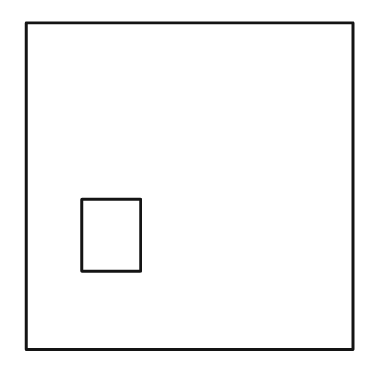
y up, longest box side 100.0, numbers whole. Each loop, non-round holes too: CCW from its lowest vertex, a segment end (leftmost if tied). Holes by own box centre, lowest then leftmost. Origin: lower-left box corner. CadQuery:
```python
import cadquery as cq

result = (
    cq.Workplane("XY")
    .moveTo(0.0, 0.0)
    .lineTo(100.0, 0.0)
    .lineTo(100.0, 100.0)
    .lineTo(0.0, 100.0)
    .close()
    .moveTo(17.0, 24.0)
    .lineTo(35.0, 24.0)
    .lineTo(35.0, 46.0)
    .lineTo(17.0, 46.0)
    .close()
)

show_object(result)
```